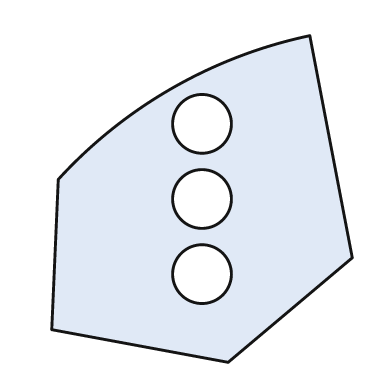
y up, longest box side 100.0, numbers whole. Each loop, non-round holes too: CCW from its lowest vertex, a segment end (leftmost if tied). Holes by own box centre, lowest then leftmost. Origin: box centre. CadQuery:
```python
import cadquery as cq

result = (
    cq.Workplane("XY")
    .moveTo(8.0, -50.0)
    .lineTo(46.0, -18.0)
    .lineTo(33.0, 50.0)
    .threePointArc((-9.0, 34.0), (-44.0, 6.0))
    .lineTo(-46.0, -40.0)
    .close()
    .moveTo(0.0, -23.0)
    .circle(9.0)
    .moveTo(0.0, 0.0)
    .circle(9.0)
    .moveTo(0.0, 23.0)
    .circle(9.0)
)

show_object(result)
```